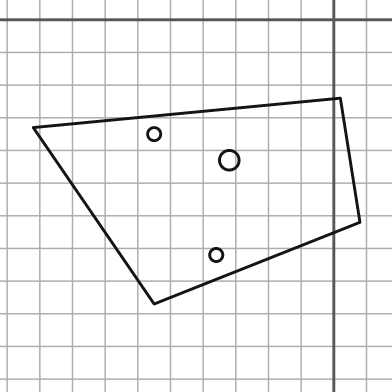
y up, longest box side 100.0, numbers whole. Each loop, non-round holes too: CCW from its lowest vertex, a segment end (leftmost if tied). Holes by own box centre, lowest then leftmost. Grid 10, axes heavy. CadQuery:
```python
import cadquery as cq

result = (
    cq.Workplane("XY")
    .moveTo(-55.0, -87.0)
    .lineTo(8.0, -62.0)
    .lineTo(2.0, -24.0)
    .lineTo(-92.0, -33.0)
    .close()
    .moveTo(-36.0, -72.0)
    .circle(2.0)
    .moveTo(-32.0, -43.0)
    .circle(3.0)
    .moveTo(-55.0, -35.0)
    .circle(2.0)
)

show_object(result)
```